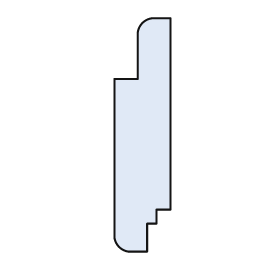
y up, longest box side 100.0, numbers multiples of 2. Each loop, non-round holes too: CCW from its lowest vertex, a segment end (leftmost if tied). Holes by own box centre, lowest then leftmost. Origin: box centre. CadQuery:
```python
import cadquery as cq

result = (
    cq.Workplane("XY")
    .moveTo(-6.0, -50.0)
    .lineTo(2.0, -50.0)
    .lineTo(2.0, -38.0)
    .lineTo(6.0, -38.0)
    .lineTo(6.0, -32.0)
    .lineTo(12.0, -32.0)
    .lineTo(12.0, 50.0)
    .lineTo(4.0, 50.0)
    .threePointArc((0.0, 48.0), (-2.0, 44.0))
    .lineTo(-2.0, 24.0)
    .lineTo(-12.0, 24.0)
    .lineTo(-12.0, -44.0)
    .threePointArc((-10.0, -48.0), (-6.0, -50.0))
    .close()
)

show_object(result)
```